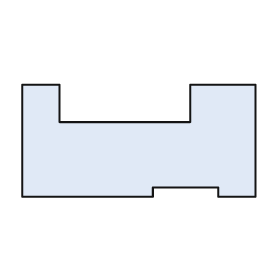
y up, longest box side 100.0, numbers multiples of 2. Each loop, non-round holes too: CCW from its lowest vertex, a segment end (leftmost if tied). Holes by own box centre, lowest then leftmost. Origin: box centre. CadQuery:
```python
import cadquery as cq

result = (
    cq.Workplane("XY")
    .moveTo(-50.0, -24.0)
    .lineTo(6.0, -24.0)
    .lineTo(6.0, -20.0)
    .lineTo(34.0, -20.0)
    .lineTo(34.0, -24.0)
    .lineTo(50.0, -24.0)
    .lineTo(50.0, 24.0)
    .lineTo(22.0, 24.0)
    .lineTo(22.0, 8.0)
    .lineTo(-34.0, 8.0)
    .lineTo(-34.0, 24.0)
    .lineTo(-50.0, 24.0)
    .close()
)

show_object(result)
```